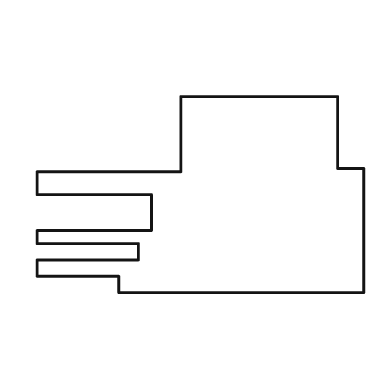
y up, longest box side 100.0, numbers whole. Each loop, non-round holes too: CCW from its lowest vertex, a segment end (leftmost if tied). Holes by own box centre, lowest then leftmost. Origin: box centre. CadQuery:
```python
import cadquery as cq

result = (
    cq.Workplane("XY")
    .moveTo(-25.0, -30.0)
    .lineTo(50.0, -30.0)
    .lineTo(50.0, 8.0)
    .lineTo(42.0, 8.0)
    .lineTo(42.0, 30.0)
    .lineTo(-6.0, 30.0)
    .lineTo(-6.0, 7.0)
    .lineTo(-50.0, 7.0)
    .lineTo(-50.0, 0.0)
    .lineTo(-15.0, 0.0)
    .lineTo(-15.0, -11.0)
    .lineTo(-50.0, -11.0)
    .lineTo(-50.0, -15.0)
    .lineTo(-19.0, -15.0)
    .lineTo(-19.0, -20.0)
    .lineTo(-50.0, -20.0)
    .lineTo(-50.0, -25.0)
    .lineTo(-25.0, -25.0)
    .close()
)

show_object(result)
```